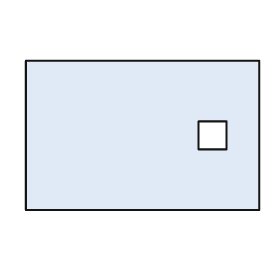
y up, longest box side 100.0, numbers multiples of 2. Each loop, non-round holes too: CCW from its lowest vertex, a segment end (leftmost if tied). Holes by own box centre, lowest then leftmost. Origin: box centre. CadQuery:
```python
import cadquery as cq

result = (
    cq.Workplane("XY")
    .moveTo(-50.0, -32.0)
    .lineTo(50.0, -32.0)
    .lineTo(50.0, 32.0)
    .lineTo(-50.0, 32.0)
    .close()
    .moveTo(24.0, -6.0)
    .lineTo(36.0, -6.0)
    .lineTo(36.0, 6.0)
    .lineTo(24.0, 6.0)
    .close()
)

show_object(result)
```